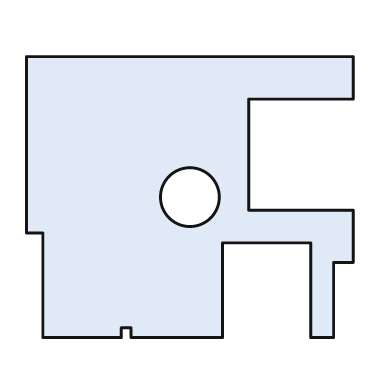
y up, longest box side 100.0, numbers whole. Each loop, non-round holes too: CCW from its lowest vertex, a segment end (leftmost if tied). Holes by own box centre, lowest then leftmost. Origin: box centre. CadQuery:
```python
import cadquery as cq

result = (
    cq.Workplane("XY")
    .moveTo(-45.0, -43.0)
    .lineTo(-21.0, -43.0)
    .lineTo(-21.0, -40.0)
    .lineTo(-18.0, -40.0)
    .lineTo(-18.0, -43.0)
    .lineTo(10.0, -43.0)
    .lineTo(10.0, -14.0)
    .lineTo(37.0, -14.0)
    .lineTo(37.0, -43.0)
    .lineTo(44.0, -43.0)
    .lineTo(44.0, -20.0)
    .lineTo(50.0, -20.0)
    .lineTo(50.0, -4.0)
    .lineTo(18.0, -4.0)
    .lineTo(18.0, 30.0)
    .lineTo(50.0, 30.0)
    .lineTo(50.0, 43.0)
    .lineTo(-50.0, 43.0)
    .lineTo(-50.0, -11.0)
    .lineTo(-45.0, -11.0)
    .close()
    .moveTo(0.0, 0.0)
    .circle(9.0)
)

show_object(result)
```